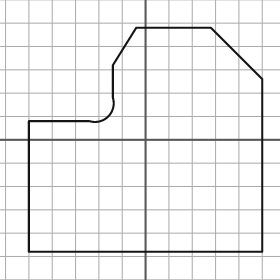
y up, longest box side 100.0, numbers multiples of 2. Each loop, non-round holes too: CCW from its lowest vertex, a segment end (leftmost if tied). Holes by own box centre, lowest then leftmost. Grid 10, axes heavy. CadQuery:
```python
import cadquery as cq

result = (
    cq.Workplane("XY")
    .moveTo(-50.0, -48.0)
    .lineTo(50.0, -48.0)
    .lineTo(50.0, 26.0)
    .lineTo(28.0, 48.0)
    .lineTo(-4.0, 48.0)
    .lineTo(-14.0, 32.0)
    .lineTo(-14.0, 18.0)
    .threePointArc((-16.0, 10.0), (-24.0, 8.0))
    .lineTo(-50.0, 8.0)
    .close()
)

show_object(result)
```